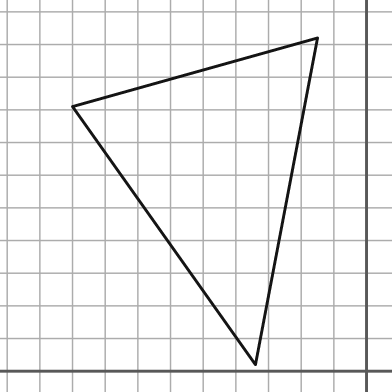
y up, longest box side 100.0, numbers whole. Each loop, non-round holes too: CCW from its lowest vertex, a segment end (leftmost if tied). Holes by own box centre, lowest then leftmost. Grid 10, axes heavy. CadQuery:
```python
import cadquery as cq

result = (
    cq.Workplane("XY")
    .moveTo(-34.0, 2.0)
    .lineTo(-15.0, 102.0)
    .lineTo(-90.0, 81.0)
    .close()
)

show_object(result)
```